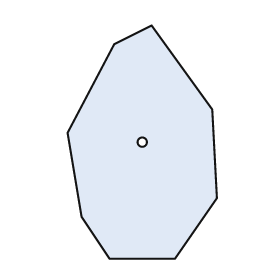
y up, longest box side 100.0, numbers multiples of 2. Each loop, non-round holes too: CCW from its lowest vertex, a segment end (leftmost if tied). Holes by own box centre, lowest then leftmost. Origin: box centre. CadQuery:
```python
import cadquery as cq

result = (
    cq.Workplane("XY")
    .moveTo(-14.0, -50.0)
    .lineTo(14.0, -50.0)
    .lineTo(32.0, -24.0)
    .lineTo(30.0, 14.0)
    .lineTo(4.0, 50.0)
    .lineTo(-12.0, 42.0)
    .lineTo(-32.0, 4.0)
    .lineTo(-26.0, -32.0)
    .close()
    .moveTo(0.0, 0.0)
    .circle(2.0)
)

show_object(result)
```